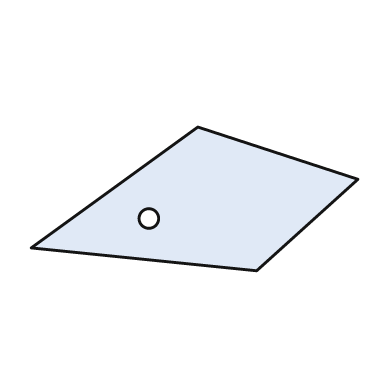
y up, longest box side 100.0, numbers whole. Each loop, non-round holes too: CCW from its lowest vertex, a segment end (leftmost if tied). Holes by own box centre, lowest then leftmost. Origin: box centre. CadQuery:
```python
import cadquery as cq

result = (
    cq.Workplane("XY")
    .moveTo(19.0, -22.0)
    .lineTo(50.0, 6.0)
    .lineTo(1.0, 22.0)
    .lineTo(-50.0, -15.0)
    .close()
    .moveTo(-14.0, -6.0)
    .circle(3.0)
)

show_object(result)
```